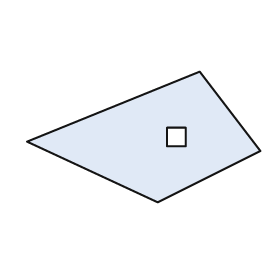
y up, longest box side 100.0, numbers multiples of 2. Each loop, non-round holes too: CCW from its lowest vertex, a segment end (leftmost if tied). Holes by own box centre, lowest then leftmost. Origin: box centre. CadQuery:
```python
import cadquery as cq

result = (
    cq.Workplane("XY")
    .moveTo(6.0, -28.0)
    .lineTo(50.0, -6.0)
    .lineTo(24.0, 28.0)
    .lineTo(-50.0, -2.0)
    .close()
    .moveTo(10.0, -4.0)
    .lineTo(18.0, -4.0)
    .lineTo(18.0, 4.0)
    .lineTo(10.0, 4.0)
    .close()
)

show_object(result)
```